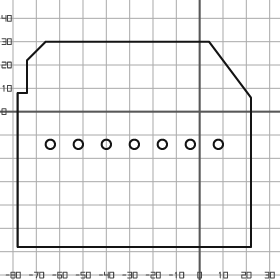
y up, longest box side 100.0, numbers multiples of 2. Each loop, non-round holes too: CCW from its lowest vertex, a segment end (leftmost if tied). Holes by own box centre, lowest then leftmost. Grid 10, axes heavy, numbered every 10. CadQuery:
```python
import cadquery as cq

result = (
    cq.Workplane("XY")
    .moveTo(-78.0, -58.0)
    .lineTo(22.0, -58.0)
    .lineTo(22.0, 6.0)
    .lineTo(4.0, 30.0)
    .lineTo(-66.0, 30.0)
    .lineTo(-74.0, 22.0)
    .lineTo(-74.0, 8.0)
    .lineTo(-78.0, 8.0)
    .close()
    .moveTo(-64.0, -14.0)
    .circle(2.0)
    .moveTo(-52.0, -14.0)
    .circle(2.0)
    .moveTo(-40.0, -14.0)
    .circle(2.0)
    .moveTo(-28.0, -14.0)
    .circle(2.0)
    .moveTo(-16.0, -14.0)
    .circle(2.0)
    .moveTo(-4.0, -14.0)
    .circle(2.0)
    .moveTo(8.0, -14.0)
    .circle(2.0)
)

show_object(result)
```